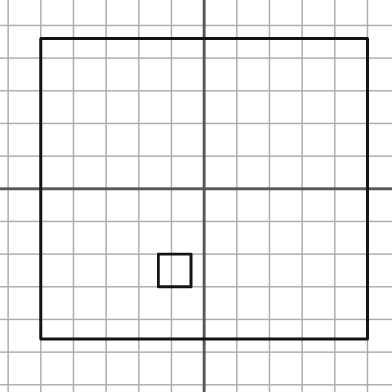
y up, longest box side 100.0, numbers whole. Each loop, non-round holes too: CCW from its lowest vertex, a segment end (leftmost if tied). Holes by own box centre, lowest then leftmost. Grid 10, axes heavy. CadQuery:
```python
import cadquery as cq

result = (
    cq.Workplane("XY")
    .moveTo(-50.0, -46.0)
    .lineTo(50.0, -46.0)
    .lineTo(50.0, 46.0)
    .lineTo(-50.0, 46.0)
    .close()
    .moveTo(-14.0, -30.0)
    .lineTo(-4.0, -30.0)
    .lineTo(-4.0, -20.0)
    .lineTo(-14.0, -20.0)
    .close()
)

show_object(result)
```